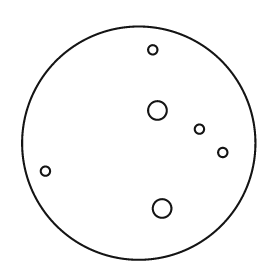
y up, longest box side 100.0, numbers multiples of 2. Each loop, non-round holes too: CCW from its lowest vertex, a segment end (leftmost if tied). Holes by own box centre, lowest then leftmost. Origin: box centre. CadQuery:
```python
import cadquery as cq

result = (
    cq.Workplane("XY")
    .moveTo(0.0, 0.0)
    .circle(50.0)
    .moveTo(10.0, -28.0)
    .circle(4.0)
    .moveTo(-40.0, -12.0)
    .circle(2.0)
    .moveTo(36.0, -4.0)
    .circle(2.0)
    .moveTo(26.0, 6.0)
    .circle(2.0)
    .moveTo(8.0, 14.0)
    .circle(4.0)
    .moveTo(6.0, 40.0)
    .circle(2.0)
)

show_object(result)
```